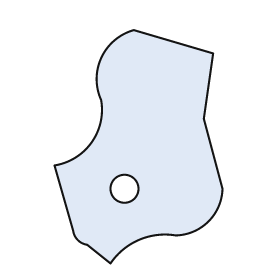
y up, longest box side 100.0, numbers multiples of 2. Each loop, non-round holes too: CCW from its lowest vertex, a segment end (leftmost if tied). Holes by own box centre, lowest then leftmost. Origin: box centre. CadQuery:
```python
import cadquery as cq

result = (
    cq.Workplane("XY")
    .moveTo(-12.0, -50.0)
    .threePointArc((0.0, -40.0), (16.0, -38.0))
    .threePointArc((30.0, -32.0), (36.0, -18.0))
    .lineTo(28.0, 12.0)
    .lineTo(32.0, 40.0)
    .lineTo(-2.0, 50.0)
    .threePointArc((-16.0, 38.0), (-16.0, 20.0))
    .threePointArc((-20.0, 2.0), (-36.0, -8.0))
    .lineTo(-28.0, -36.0)
    .threePointArc((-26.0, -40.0), (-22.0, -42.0))
    .close()
    .moveTo(-6.0, -18.0)
    .circle(6.0)
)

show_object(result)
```